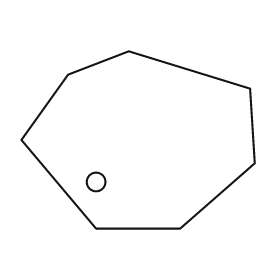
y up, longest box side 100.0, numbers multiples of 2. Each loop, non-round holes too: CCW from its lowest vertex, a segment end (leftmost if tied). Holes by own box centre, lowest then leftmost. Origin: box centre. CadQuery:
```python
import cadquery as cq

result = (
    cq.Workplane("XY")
    .moveTo(-18.0, -38.0)
    .lineTo(18.0, -38.0)
    .lineTo(50.0, -10.0)
    .lineTo(48.0, 22.0)
    .lineTo(-4.0, 38.0)
    .lineTo(-30.0, 28.0)
    .lineTo(-50.0, 0.0)
    .close()
    .moveTo(-18.0, -18.0)
    .circle(4.0)
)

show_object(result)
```